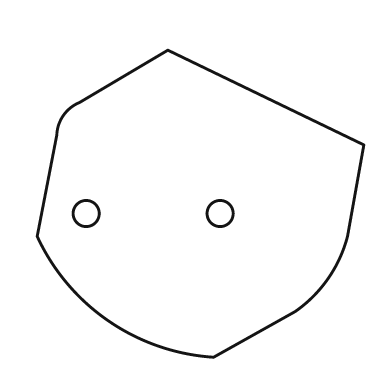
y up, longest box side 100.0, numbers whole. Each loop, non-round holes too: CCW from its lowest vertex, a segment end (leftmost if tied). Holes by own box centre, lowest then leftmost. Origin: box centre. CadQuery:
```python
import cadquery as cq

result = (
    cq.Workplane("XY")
    .moveTo(4.0, -47.0)
    .lineTo(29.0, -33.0)
    .threePointArc((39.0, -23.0), (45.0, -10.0))
    .lineTo(50.0, 18.0)
    .lineTo(-10.0, 47.0)
    .lineTo(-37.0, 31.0)
    .threePointArc((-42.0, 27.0), (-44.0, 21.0))
    .lineTo(-50.0, -10.0)
    .threePointArc((-28.0, -36.0), (4.0, -47.0))
    .close()
    .moveTo(-35.0, -3.0)
    .circle(4.0)
    .moveTo(6.0, -3.0)
    .circle(4.0)
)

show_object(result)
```